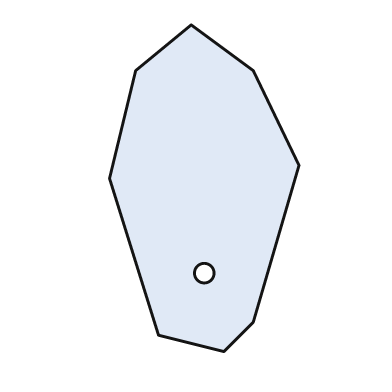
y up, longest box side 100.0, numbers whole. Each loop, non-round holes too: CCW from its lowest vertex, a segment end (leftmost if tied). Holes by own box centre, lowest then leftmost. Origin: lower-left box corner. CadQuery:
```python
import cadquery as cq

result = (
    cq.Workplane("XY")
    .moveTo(35.0, 0.0)
    .lineTo(44.0, 9.0)
    .lineTo(58.0, 57.0)
    .lineTo(44.0, 86.0)
    .lineTo(25.0, 100.0)
    .lineTo(8.0, 86.0)
    .lineTo(0.0, 53.0)
    .lineTo(15.0, 5.0)
    .close()
    .moveTo(29.0, 24.0)
    .circle(3.0)
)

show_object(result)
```